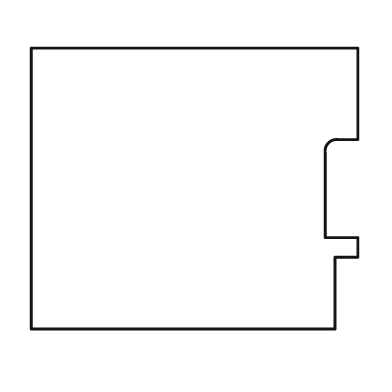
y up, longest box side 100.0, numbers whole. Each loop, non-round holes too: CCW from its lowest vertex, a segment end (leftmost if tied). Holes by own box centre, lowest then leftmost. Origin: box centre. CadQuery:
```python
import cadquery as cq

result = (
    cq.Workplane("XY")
    .moveTo(-50.0, -43.0)
    .lineTo(43.0, -43.0)
    .lineTo(43.0, -21.0)
    .lineTo(50.0, -21.0)
    .lineTo(50.0, -15.0)
    .lineTo(40.0, -15.0)
    .lineTo(40.0, 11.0)
    .threePointArc((41.0, 14.0), (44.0, 15.0))
    .lineTo(50.0, 15.0)
    .lineTo(50.0, 43.0)
    .lineTo(-50.0, 43.0)
    .close()
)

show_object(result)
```